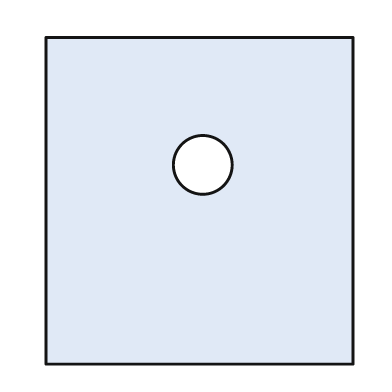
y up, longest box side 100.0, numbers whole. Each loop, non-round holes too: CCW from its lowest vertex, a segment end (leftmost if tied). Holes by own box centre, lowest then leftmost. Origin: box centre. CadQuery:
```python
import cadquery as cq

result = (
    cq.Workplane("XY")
    .moveTo(-47.0, -50.0)
    .lineTo(47.0, -50.0)
    .lineTo(47.0, 50.0)
    .lineTo(-47.0, 50.0)
    .close()
    .moveTo(1.0, 11.0)
    .circle(9.0)
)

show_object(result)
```